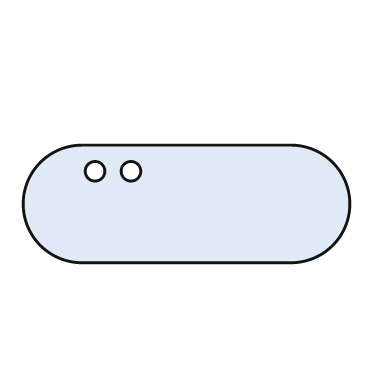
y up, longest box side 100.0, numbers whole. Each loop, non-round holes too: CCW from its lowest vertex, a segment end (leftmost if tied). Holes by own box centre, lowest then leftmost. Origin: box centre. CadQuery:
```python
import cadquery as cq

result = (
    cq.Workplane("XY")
    .moveTo(-32.0, -18.0)
    .lineTo(32.0, -18.0)
    .threePointArc((50.0, 0.0), (32.0, 18.0))
    .lineTo(-32.0, 18.0)
    .threePointArc((-50.0, 0.0), (-32.0, -18.0))
    .close()
    .moveTo(-28.0, 10.0)
    .circle(3.0)
    .moveTo(-17.0, 10.0)
    .circle(3.0)
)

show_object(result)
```